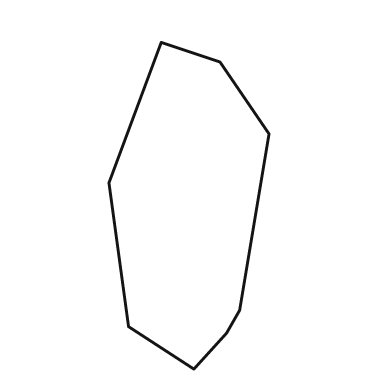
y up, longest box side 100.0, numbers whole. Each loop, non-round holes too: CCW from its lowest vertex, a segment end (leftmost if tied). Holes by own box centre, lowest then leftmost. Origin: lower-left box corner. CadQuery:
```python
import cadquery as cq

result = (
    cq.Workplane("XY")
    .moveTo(26.0, 0.0)
    .lineTo(36.0, 11.0)
    .lineTo(40.0, 18.0)
    .lineTo(49.0, 72.0)
    .lineTo(34.0, 94.0)
    .lineTo(16.0, 100.0)
    .lineTo(0.0, 57.0)
    .lineTo(6.0, 13.0)
    .close()
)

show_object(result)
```